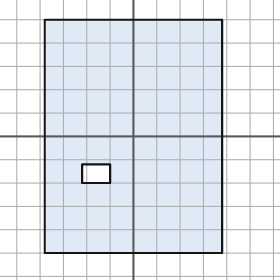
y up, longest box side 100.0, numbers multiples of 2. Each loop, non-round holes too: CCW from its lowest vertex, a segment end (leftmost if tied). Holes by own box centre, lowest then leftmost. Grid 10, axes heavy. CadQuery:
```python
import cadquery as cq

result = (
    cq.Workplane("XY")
    .moveTo(-38.0, -50.0)
    .lineTo(38.0, -50.0)
    .lineTo(38.0, 50.0)
    .lineTo(-38.0, 50.0)
    .close()
    .moveTo(-22.0, -20.0)
    .lineTo(-10.0, -20.0)
    .lineTo(-10.0, -12.0)
    .lineTo(-22.0, -12.0)
    .close()
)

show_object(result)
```